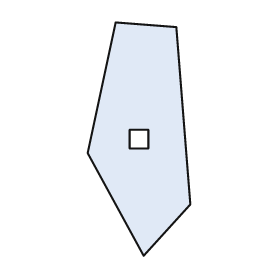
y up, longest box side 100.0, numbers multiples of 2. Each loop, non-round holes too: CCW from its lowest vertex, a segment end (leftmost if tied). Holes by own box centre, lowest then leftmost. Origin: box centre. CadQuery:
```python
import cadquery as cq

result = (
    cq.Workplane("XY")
    .moveTo(2.0, -50.0)
    .lineTo(22.0, -28.0)
    .lineTo(16.0, 48.0)
    .lineTo(-10.0, 50.0)
    .lineTo(-22.0, -6.0)
    .close()
    .moveTo(-4.0, -4.0)
    .lineTo(4.0, -4.0)
    .lineTo(4.0, 4.0)
    .lineTo(-4.0, 4.0)
    .close()
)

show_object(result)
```